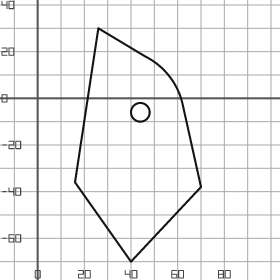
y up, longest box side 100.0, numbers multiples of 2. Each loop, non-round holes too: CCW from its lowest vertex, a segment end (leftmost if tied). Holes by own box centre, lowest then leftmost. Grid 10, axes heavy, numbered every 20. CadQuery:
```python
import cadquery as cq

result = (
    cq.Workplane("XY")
    .moveTo(40.0, -70.0)
    .lineTo(70.0, -38.0)
    .lineTo(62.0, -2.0)
    .threePointArc((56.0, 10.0), (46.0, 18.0))
    .lineTo(26.0, 30.0)
    .lineTo(16.0, -36.0)
    .close()
    .moveTo(44.0, -6.0)
    .circle(4.0)
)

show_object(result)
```